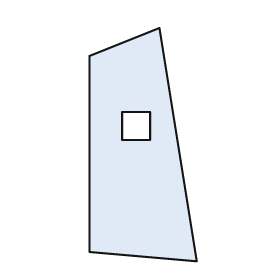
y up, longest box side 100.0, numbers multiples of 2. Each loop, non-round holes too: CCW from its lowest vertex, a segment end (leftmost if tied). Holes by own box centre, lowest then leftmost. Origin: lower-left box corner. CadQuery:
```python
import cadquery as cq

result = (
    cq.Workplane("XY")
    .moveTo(46.0, 0.0)
    .lineTo(30.0, 100.0)
    .lineTo(0.0, 88.0)
    .lineTo(0.0, 4.0)
    .close()
    .moveTo(14.0, 52.0)
    .lineTo(26.0, 52.0)
    .lineTo(26.0, 64.0)
    .lineTo(14.0, 64.0)
    .close()
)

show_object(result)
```